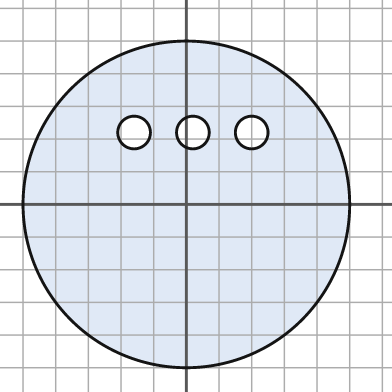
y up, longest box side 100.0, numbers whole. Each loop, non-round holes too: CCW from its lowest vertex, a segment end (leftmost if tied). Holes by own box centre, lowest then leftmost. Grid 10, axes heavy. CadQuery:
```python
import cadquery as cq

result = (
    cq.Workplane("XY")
    .moveTo(0.0, 0.0)
    .circle(50.0)
    .moveTo(-16.0, 22.0)
    .circle(5.0)
    .moveTo(2.0, 22.0)
    .circle(5.0)
    .moveTo(20.0, 22.0)
    .circle(5.0)
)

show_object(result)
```